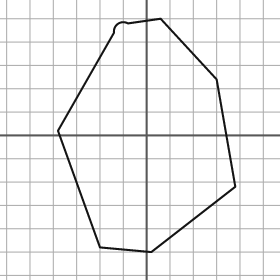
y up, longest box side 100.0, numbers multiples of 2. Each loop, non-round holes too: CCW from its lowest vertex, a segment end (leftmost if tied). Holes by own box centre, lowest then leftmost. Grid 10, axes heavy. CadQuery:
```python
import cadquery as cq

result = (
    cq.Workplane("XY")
    .moveTo(2.0, -50.0)
    .lineTo(38.0, -22.0)
    .lineTo(30.0, 24.0)
    .lineTo(6.0, 50.0)
    .lineTo(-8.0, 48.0)
    .threePointArc((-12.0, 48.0), (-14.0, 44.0))
    .lineTo(-38.0, 2.0)
    .lineTo(-20.0, -48.0)
    .close()
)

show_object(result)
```